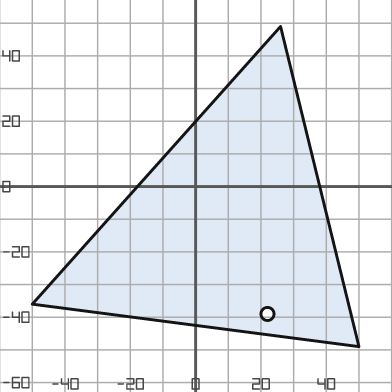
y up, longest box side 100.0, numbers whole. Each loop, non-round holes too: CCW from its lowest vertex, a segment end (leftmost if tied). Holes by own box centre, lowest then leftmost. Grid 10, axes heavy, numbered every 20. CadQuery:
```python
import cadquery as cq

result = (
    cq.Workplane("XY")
    .moveTo(50.0, -49.0)
    .lineTo(26.0, 49.0)
    .lineTo(-50.0, -36.0)
    .close()
    .moveTo(22.0, -39.0)
    .circle(2.0)
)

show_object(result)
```